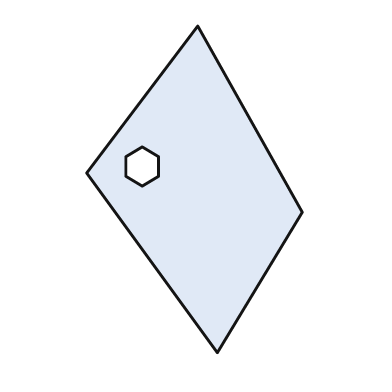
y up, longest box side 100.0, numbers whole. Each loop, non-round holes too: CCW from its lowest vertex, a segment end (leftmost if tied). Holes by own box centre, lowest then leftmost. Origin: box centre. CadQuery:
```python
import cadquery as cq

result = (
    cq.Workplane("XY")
    .moveTo(7.0, -50.0)
    .lineTo(33.0, -7.0)
    .lineTo(1.0, 50.0)
    .lineTo(-33.0, 5.0)
    .close()
    .moveTo(-16.0, 1.0)
    .lineTo(-11.0, 4.0)
    .lineTo(-11.0, 10.0)
    .lineTo(-16.0, 13.0)
    .lineTo(-21.0, 10.0)
    .lineTo(-21.0, 4.0)
    .close()
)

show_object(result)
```